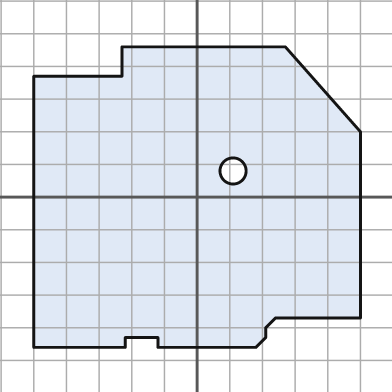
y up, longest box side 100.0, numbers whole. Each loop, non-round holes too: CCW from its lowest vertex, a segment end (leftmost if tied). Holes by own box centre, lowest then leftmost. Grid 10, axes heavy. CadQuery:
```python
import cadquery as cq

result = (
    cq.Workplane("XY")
    .moveTo(-50.0, -46.0)
    .lineTo(-22.0, -46.0)
    .lineTo(-22.0, -43.0)
    .lineTo(-12.0, -43.0)
    .lineTo(-12.0, -46.0)
    .lineTo(18.0, -46.0)
    .lineTo(21.0, -43.0)
    .lineTo(21.0, -40.0)
    .lineTo(24.0, -37.0)
    .lineTo(50.0, -37.0)
    .lineTo(50.0, 20.0)
    .lineTo(27.0, 46.0)
    .lineTo(-23.0, 46.0)
    .lineTo(-23.0, 37.0)
    .lineTo(-50.0, 37.0)
    .close()
    .moveTo(11.0, 8.0)
    .circle(4.0)
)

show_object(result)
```